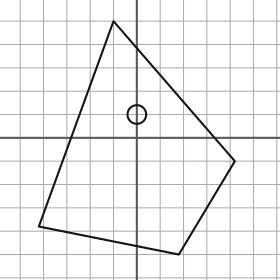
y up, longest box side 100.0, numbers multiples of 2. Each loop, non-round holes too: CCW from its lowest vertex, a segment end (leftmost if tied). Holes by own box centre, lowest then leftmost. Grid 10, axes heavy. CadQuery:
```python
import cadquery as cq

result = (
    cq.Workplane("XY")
    .moveTo(18.0, -50.0)
    .lineTo(42.0, -10.0)
    .lineTo(-10.0, 50.0)
    .lineTo(-42.0, -38.0)
    .close()
    .moveTo(0.0, 10.0)
    .circle(4.0)
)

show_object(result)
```